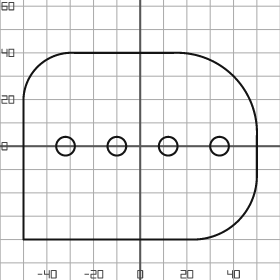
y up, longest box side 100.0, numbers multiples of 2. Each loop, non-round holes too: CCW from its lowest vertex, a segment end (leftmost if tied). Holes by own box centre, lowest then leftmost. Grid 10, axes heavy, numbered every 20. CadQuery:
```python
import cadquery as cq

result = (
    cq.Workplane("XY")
    .moveTo(-50.0, -40.0)
    .lineTo(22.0, -40.0)
    .threePointArc((42.0, -32.0), (50.0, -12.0))
    .lineTo(50.0, 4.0)
    .threePointArc((40.0, 30.0), (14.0, 40.0))
    .lineTo(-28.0, 40.0)
    .threePointArc((-44.0, 34.0), (-50.0, 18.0))
    .close()
    .moveTo(-32.0, 0.0)
    .circle(4.0)
    .moveTo(-10.0, 0.0)
    .circle(4.0)
    .moveTo(12.0, 0.0)
    .circle(4.0)
    .moveTo(34.0, 0.0)
    .circle(4.0)
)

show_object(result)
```